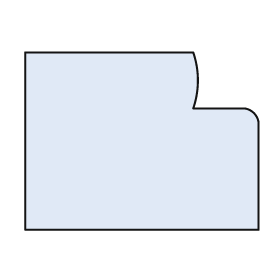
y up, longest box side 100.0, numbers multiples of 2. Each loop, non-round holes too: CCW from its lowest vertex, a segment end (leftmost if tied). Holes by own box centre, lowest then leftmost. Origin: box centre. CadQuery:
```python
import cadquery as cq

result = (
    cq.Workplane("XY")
    .moveTo(-50.0, -38.0)
    .lineTo(50.0, -38.0)
    .lineTo(50.0, 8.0)
    .threePointArc((48.0, 12.0), (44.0, 14.0))
    .lineTo(22.0, 14.0)
    .threePointArc((24.0, 26.0), (22.0, 38.0))
    .lineTo(-50.0, 38.0)
    .close()
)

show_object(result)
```